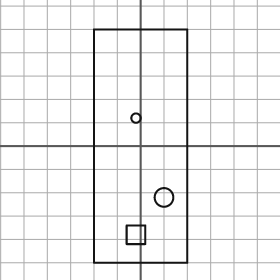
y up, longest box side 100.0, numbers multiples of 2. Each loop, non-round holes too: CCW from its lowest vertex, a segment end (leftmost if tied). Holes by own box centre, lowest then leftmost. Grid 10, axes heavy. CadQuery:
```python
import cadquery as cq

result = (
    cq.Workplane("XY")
    .moveTo(-20.0, -50.0)
    .lineTo(20.0, -50.0)
    .lineTo(20.0, 50.0)
    .lineTo(-20.0, 50.0)
    .close()
    .moveTo(-6.0, -42.0)
    .lineTo(2.0, -42.0)
    .lineTo(2.0, -34.0)
    .lineTo(-6.0, -34.0)
    .close()
    .moveTo(10.0, -22.0)
    .circle(4.0)
    .moveTo(-2.0, 12.0)
    .circle(2.0)
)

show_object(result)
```